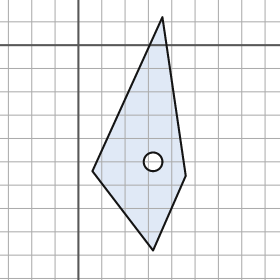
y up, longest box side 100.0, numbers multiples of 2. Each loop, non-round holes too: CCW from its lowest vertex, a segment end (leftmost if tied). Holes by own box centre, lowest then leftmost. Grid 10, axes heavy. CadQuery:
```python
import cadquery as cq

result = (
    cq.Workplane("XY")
    .moveTo(32.0, -88.0)
    .lineTo(46.0, -56.0)
    .lineTo(36.0, 12.0)
    .lineTo(6.0, -54.0)
    .close()
    .moveTo(32.0, -50.0)
    .circle(4.0)
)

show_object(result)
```